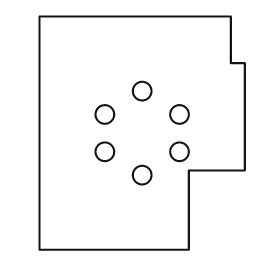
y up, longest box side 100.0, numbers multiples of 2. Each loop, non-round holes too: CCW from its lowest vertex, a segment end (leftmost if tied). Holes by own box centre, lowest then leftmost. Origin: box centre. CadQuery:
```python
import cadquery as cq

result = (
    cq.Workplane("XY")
    .moveTo(-44.0, -50.0)
    .lineTo(20.0, -50.0)
    .lineTo(20.0, -16.0)
    .lineTo(44.0, -16.0)
    .lineTo(44.0, 30.0)
    .lineTo(38.0, 30.0)
    .lineTo(38.0, 50.0)
    .lineTo(-44.0, 50.0)
    .close()
    .moveTo(0.0, -18.0)
    .circle(4.0)
    .moveTo(-16.0, -8.0)
    .circle(4.0)
    .moveTo(16.0, -8.0)
    .circle(4.0)
    .moveTo(-16.0, 8.0)
    .circle(4.0)
    .moveTo(16.0, 8.0)
    .circle(4.0)
    .moveTo(0.0, 18.0)
    .circle(4.0)
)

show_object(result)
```